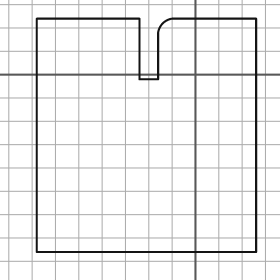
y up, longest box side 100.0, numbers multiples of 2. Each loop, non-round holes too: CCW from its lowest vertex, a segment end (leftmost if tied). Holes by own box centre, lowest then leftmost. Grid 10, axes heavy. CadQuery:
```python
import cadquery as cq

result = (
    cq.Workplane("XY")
    .moveTo(-68.0, -76.0)
    .lineTo(26.0, -76.0)
    .lineTo(26.0, 24.0)
    .lineTo(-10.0, 24.0)
    .threePointArc((-14.0, 22.0), (-16.0, 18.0))
    .lineTo(-16.0, -2.0)
    .lineTo(-24.0, -2.0)
    .lineTo(-24.0, 24.0)
    .lineTo(-68.0, 24.0)
    .close()
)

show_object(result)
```